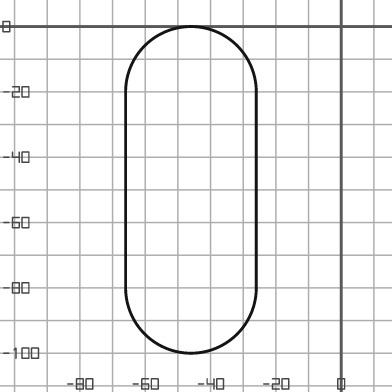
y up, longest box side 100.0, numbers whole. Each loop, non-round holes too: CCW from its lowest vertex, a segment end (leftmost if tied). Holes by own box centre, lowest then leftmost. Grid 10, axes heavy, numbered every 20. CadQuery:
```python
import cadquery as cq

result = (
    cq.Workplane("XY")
    .moveTo(-66.0, -80.0)
    .threePointArc((-46.0, -100.0), (-26.0, -80.0))
    .lineTo(-26.0, -20.0)
    .threePointArc((-46.0, 0.0), (-66.0, -20.0))
    .close()
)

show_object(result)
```